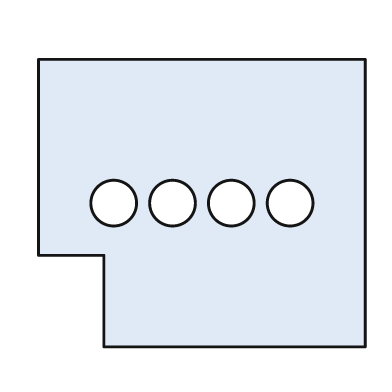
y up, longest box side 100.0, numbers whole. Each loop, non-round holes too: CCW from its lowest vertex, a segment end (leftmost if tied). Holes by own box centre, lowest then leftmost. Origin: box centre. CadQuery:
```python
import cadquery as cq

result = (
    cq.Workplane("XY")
    .moveTo(-30.0, -44.0)
    .lineTo(50.0, -44.0)
    .lineTo(50.0, 44.0)
    .lineTo(-50.0, 44.0)
    .lineTo(-50.0, -16.0)
    .lineTo(-30.0, -16.0)
    .close()
    .moveTo(-27.0, 0.0)
    .circle(7.0)
    .moveTo(-9.0, 0.0)
    .circle(7.0)
    .moveTo(9.0, 0.0)
    .circle(7.0)
    .moveTo(27.0, 0.0)
    .circle(7.0)
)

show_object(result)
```